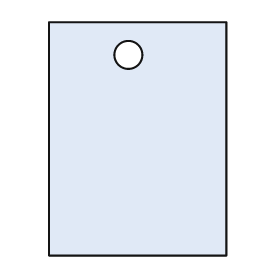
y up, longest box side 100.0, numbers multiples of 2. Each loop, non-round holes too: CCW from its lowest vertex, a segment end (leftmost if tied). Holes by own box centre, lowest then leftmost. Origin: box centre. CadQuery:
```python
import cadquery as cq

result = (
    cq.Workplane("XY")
    .moveTo(-38.0, -50.0)
    .lineTo(38.0, -50.0)
    .lineTo(38.0, 50.0)
    .lineTo(-38.0, 50.0)
    .close()
    .moveTo(-4.0, 36.0)
    .circle(6.0)
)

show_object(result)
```